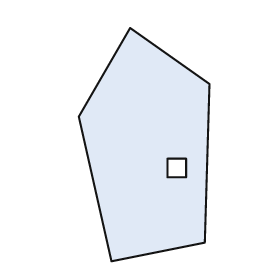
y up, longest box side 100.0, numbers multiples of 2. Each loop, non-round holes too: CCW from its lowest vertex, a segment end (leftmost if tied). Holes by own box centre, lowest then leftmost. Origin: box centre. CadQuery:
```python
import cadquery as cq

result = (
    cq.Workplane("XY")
    .moveTo(-14.0, -50.0)
    .lineTo(26.0, -42.0)
    .lineTo(28.0, 26.0)
    .lineTo(-6.0, 50.0)
    .lineTo(-28.0, 12.0)
    .close()
    .moveTo(10.0, -14.0)
    .lineTo(18.0, -14.0)
    .lineTo(18.0, -6.0)
    .lineTo(10.0, -6.0)
    .close()
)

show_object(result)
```